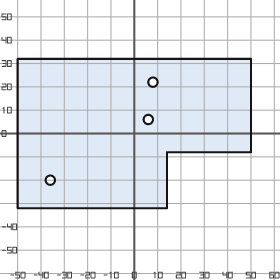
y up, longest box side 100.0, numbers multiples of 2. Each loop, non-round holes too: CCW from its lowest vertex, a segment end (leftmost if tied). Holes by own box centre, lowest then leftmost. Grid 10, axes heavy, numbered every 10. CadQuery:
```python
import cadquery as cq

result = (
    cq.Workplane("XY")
    .moveTo(-50.0, -32.0)
    .lineTo(14.0, -32.0)
    .lineTo(14.0, -8.0)
    .lineTo(50.0, -8.0)
    .lineTo(50.0, 32.0)
    .lineTo(-50.0, 32.0)
    .close()
    .moveTo(-36.0, -20.0)
    .circle(2.0)
    .moveTo(6.0, 6.0)
    .circle(2.0)
    .moveTo(8.0, 22.0)
    .circle(2.0)
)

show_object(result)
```